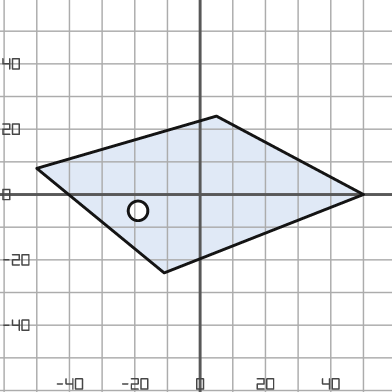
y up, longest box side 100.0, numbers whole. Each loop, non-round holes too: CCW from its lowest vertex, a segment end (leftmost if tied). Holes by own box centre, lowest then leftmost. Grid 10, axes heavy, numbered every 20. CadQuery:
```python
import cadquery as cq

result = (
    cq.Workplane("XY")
    .moveTo(-11.0, -24.0)
    .lineTo(50.0, 0.0)
    .lineTo(5.0, 24.0)
    .lineTo(-50.0, 8.0)
    .close()
    .moveTo(-19.0, -5.0)
    .circle(3.0)
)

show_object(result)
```